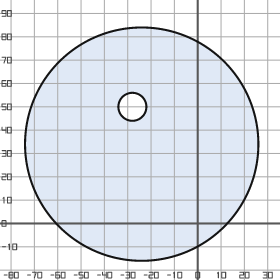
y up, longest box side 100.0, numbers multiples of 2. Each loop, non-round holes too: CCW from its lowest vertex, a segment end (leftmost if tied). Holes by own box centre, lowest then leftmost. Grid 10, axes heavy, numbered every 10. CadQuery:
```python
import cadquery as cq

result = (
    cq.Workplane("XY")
    .moveTo(-24.0, 34.0)
    .circle(50.0)
    .moveTo(-28.0, 50.0)
    .circle(6.0)
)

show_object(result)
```